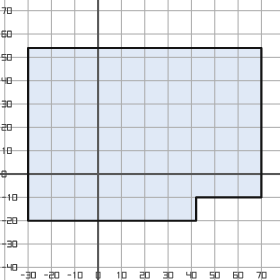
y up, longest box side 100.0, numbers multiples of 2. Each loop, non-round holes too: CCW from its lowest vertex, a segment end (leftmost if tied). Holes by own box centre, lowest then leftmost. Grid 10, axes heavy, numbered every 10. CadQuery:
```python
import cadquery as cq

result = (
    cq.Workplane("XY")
    .moveTo(-30.0, -20.0)
    .lineTo(42.0, -20.0)
    .lineTo(42.0, -10.0)
    .lineTo(70.0, -10.0)
    .lineTo(70.0, 54.0)
    .lineTo(-30.0, 54.0)
    .close()
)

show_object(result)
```